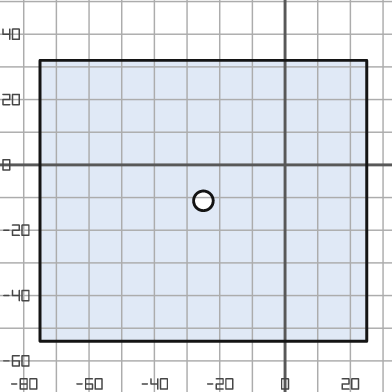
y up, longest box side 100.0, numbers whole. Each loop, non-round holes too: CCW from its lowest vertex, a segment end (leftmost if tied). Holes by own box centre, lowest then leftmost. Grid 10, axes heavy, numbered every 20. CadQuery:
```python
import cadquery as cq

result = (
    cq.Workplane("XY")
    .moveTo(-75.0, -54.0)
    .lineTo(25.0, -54.0)
    .lineTo(25.0, 32.0)
    .lineTo(-75.0, 32.0)
    .close()
    .moveTo(-25.0, -11.0)
    .circle(3.0)
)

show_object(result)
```